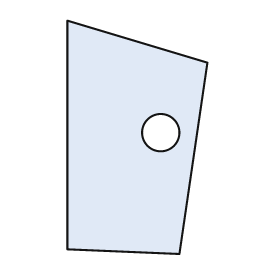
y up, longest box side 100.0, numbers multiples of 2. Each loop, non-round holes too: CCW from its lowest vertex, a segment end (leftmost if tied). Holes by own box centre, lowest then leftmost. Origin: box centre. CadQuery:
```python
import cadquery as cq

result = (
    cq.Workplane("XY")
    .moveTo(18.0, -50.0)
    .lineTo(30.0, 32.0)
    .lineTo(-30.0, 50.0)
    .lineTo(-30.0, -48.0)
    .close()
    .moveTo(10.0, 2.0)
    .circle(8.0)
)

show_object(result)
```